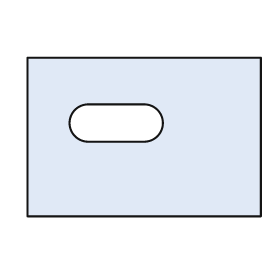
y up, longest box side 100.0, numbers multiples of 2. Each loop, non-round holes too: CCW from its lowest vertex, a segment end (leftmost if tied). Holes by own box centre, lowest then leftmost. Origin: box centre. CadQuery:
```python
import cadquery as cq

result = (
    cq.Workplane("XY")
    .moveTo(-50.0, -34.0)
    .lineTo(50.0, -34.0)
    .lineTo(50.0, 34.0)
    .lineTo(-50.0, 34.0)
    .close()
    .moveTo(-24.0, -2.0)
    .lineTo(0.0, -2.0)
    .threePointArc((8.0, 6.0), (0.0, 14.0))
    .lineTo(-24.0, 14.0)
    .threePointArc((-32.0, 6.0), (-24.0, -2.0))
    .close()
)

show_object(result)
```